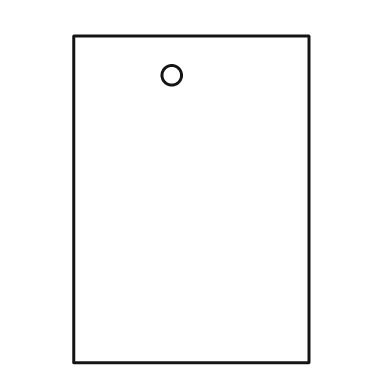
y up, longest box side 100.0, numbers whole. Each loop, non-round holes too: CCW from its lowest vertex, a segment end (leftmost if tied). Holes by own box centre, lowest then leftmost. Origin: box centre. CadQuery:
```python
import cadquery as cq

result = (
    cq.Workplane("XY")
    .moveTo(-36.0, -50.0)
    .lineTo(36.0, -50.0)
    .lineTo(36.0, 50.0)
    .lineTo(-36.0, 50.0)
    .close()
    .moveTo(-6.0, 38.0)
    .circle(3.0)
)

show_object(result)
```